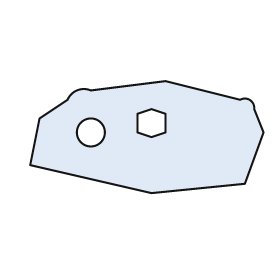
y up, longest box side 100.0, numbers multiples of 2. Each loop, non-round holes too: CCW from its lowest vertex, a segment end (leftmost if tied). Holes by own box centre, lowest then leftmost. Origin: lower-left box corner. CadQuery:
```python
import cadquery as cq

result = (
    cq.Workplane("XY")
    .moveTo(52.0, 0.0)
    .lineTo(92.0, 4.0)
    .lineTo(100.0, 26.0)
    .lineTo(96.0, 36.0)
    .threePointArc((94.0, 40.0), (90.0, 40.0))
    .lineTo(58.0, 48.0)
    .lineTo(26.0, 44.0)
    .threePointArc((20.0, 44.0), (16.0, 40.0))
    .lineTo(4.0, 32.0)
    .lineTo(0.0, 12.0)
    .close()
    .moveTo(26.0, 26.0)
    .circle(6.0)
    .moveTo(52.0, 24.0)
    .lineTo(58.0, 26.0)
    .lineTo(58.0, 34.0)
    .lineTo(52.0, 36.0)
    .lineTo(46.0, 34.0)
    .lineTo(46.0, 26.0)
    .close()
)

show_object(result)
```